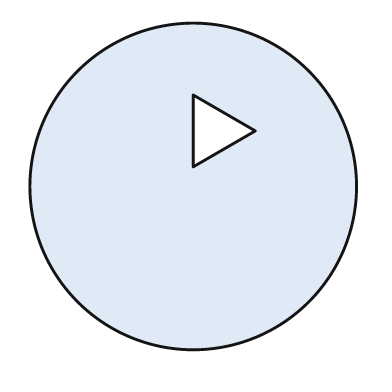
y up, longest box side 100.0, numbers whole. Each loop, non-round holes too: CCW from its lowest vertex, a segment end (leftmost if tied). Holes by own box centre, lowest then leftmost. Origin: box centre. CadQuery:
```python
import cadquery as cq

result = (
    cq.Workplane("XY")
    .moveTo(0.0, 0.0)
    .circle(50.0)
    .moveTo(0.0, 6.0)
    .lineTo(19.0, 17.0)
    .lineTo(0.0, 28.0)
    .close()
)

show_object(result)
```